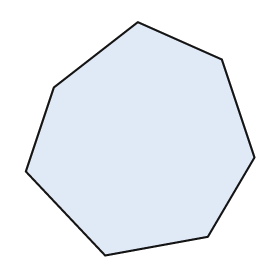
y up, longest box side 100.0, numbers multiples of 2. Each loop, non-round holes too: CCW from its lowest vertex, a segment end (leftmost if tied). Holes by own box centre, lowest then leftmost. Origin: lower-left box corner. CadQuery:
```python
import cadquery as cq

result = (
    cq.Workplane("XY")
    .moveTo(34.0, 0.0)
    .lineTo(78.0, 8.0)
    .lineTo(98.0, 42.0)
    .lineTo(84.0, 84.0)
    .lineTo(48.0, 100.0)
    .lineTo(12.0, 72.0)
    .lineTo(0.0, 36.0)
    .close()
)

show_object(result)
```